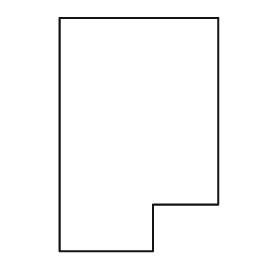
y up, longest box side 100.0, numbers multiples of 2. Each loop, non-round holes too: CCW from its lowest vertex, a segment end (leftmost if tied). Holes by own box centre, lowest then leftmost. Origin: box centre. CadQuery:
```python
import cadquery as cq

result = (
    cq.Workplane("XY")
    .moveTo(-34.0, -50.0)
    .lineTo(6.0, -50.0)
    .lineTo(6.0, -30.0)
    .lineTo(34.0, -30.0)
    .lineTo(34.0, 50.0)
    .lineTo(-34.0, 50.0)
    .close()
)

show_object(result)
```